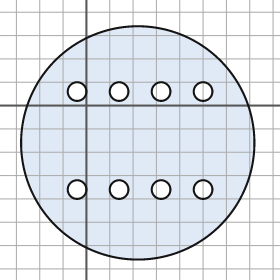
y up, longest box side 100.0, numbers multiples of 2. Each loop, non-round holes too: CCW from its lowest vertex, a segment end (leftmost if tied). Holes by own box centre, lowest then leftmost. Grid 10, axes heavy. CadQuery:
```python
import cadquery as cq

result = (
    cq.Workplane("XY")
    .moveTo(22.0, -16.0)
    .circle(50.0)
    .moveTo(-4.0, -36.0)
    .circle(4.0)
    .moveTo(14.0, -36.0)
    .circle(4.0)
    .moveTo(32.0, -36.0)
    .circle(4.0)
    .moveTo(50.0, -36.0)
    .circle(4.0)
    .moveTo(-4.0, 6.0)
    .circle(4.0)
    .moveTo(14.0, 6.0)
    .circle(4.0)
    .moveTo(32.0, 6.0)
    .circle(4.0)
    .moveTo(50.0, 6.0)
    .circle(4.0)
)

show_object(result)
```